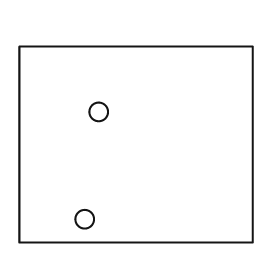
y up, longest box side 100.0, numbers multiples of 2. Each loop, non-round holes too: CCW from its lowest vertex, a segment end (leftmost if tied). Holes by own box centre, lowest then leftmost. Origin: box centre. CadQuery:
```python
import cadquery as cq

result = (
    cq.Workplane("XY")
    .moveTo(-50.0, -42.0)
    .lineTo(50.0, -42.0)
    .lineTo(50.0, 42.0)
    .lineTo(-50.0, 42.0)
    .close()
    .moveTo(-22.0, -32.0)
    .circle(4.0)
    .moveTo(-16.0, 14.0)
    .circle(4.0)
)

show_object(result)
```